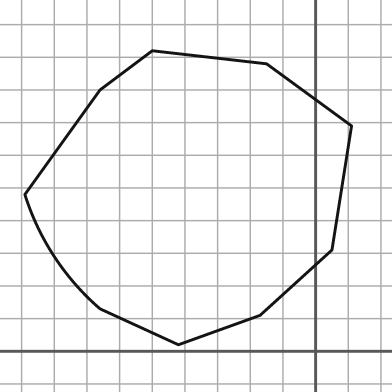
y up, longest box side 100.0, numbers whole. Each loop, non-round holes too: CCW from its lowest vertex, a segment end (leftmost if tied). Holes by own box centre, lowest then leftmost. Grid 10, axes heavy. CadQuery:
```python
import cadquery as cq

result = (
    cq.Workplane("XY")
    .moveTo(-42.0, 2.0)
    .lineTo(-17.0, 11.0)
    .lineTo(5.0, 31.0)
    .lineTo(11.0, 69.0)
    .lineTo(-15.0, 88.0)
    .lineTo(-50.0, 92.0)
    .lineTo(-66.0, 80.0)
    .lineTo(-89.0, 48.0)
    .threePointArc((-80.0, 29.0), (-66.0, 13.0))
    .close()
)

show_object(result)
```